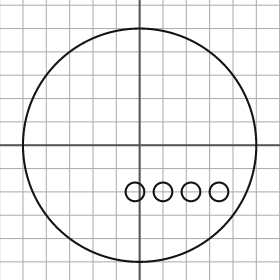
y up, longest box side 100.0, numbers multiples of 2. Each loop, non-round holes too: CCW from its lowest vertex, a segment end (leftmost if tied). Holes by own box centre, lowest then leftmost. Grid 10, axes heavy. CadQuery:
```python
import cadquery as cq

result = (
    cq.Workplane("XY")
    .moveTo(0.0, 0.0)
    .circle(50.0)
    .moveTo(-2.0, -20.0)
    .circle(4.0)
    .moveTo(10.0, -20.0)
    .circle(4.0)
    .moveTo(22.0, -20.0)
    .circle(4.0)
    .moveTo(34.0, -20.0)
    .circle(4.0)
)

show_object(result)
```